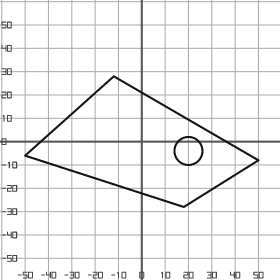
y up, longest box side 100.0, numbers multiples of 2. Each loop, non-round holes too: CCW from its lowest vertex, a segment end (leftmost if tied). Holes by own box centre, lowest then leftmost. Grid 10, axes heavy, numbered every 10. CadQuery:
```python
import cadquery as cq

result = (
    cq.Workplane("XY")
    .moveTo(18.0, -28.0)
    .lineTo(50.0, -8.0)
    .lineTo(-12.0, 28.0)
    .lineTo(-50.0, -6.0)
    .close()
    .moveTo(20.0, -4.0)
    .circle(6.0)
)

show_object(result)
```